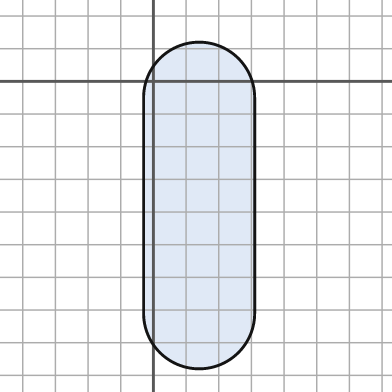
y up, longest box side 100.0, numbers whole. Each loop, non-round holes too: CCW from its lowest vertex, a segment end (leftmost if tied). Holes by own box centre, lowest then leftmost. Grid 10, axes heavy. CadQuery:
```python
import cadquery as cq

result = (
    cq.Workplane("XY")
    .moveTo(-3.0, -71.0)
    .threePointArc((14.0, -88.0), (31.0, -71.0))
    .lineTo(31.0, -5.0)
    .threePointArc((14.0, 12.0), (-3.0, -5.0))
    .close()
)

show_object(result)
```